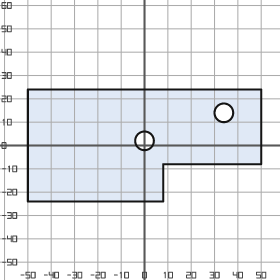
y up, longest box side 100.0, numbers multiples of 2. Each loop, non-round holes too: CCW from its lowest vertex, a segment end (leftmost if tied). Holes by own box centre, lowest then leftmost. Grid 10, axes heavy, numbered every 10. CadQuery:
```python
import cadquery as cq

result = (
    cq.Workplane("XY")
    .moveTo(-50.0, -24.0)
    .lineTo(8.0, -24.0)
    .lineTo(8.0, -8.0)
    .lineTo(50.0, -8.0)
    .lineTo(50.0, 24.0)
    .lineTo(-50.0, 24.0)
    .close()
    .moveTo(0.0, 2.0)
    .circle(4.0)
    .moveTo(34.0, 14.0)
    .circle(4.0)
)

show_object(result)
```